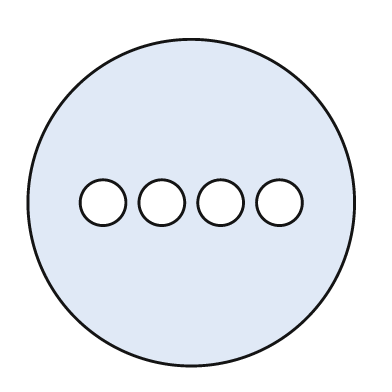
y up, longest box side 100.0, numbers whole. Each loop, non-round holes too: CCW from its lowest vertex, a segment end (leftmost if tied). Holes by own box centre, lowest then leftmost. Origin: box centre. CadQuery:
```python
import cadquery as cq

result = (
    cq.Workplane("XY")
    .moveTo(0.0, 0.0)
    .circle(50.0)
    .moveTo(-27.0, 0.0)
    .circle(7.0)
    .moveTo(-9.0, 0.0)
    .circle(7.0)
    .moveTo(9.0, 0.0)
    .circle(7.0)
    .moveTo(27.0, 0.0)
    .circle(7.0)
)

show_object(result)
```